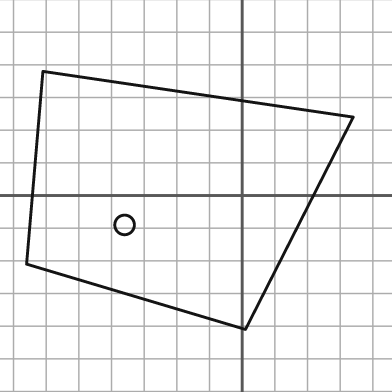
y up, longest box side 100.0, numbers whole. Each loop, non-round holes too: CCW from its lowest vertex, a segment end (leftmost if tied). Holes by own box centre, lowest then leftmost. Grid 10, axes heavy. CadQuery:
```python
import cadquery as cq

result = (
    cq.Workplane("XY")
    .moveTo(1.0, -41.0)
    .lineTo(34.0, 24.0)
    .lineTo(-61.0, 38.0)
    .lineTo(-66.0, -21.0)
    .close()
    .moveTo(-36.0, -9.0)
    .circle(3.0)
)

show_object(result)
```